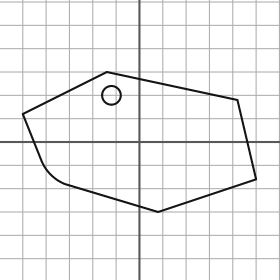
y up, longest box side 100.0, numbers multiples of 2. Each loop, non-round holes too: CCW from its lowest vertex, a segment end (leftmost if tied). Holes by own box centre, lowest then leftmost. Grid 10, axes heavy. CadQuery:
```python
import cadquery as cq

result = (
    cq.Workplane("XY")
    .moveTo(8.0, -30.0)
    .lineTo(50.0, -16.0)
    .lineTo(42.0, 18.0)
    .lineTo(-14.0, 30.0)
    .lineTo(-50.0, 12.0)
    .lineTo(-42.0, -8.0)
    .threePointArc((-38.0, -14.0), (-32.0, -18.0))
    .close()
    .moveTo(-12.0, 20.0)
    .circle(4.0)
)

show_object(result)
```